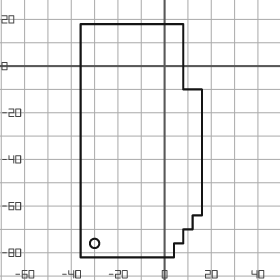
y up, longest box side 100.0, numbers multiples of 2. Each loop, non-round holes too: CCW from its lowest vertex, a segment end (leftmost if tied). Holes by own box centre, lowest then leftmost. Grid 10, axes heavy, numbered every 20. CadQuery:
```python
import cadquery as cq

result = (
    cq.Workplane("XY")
    .moveTo(-36.0, -82.0)
    .lineTo(4.0, -82.0)
    .lineTo(4.0, -76.0)
    .lineTo(8.0, -76.0)
    .lineTo(8.0, -70.0)
    .lineTo(12.0, -70.0)
    .lineTo(12.0, -64.0)
    .lineTo(16.0, -64.0)
    .lineTo(16.0, -10.0)
    .lineTo(8.0, -10.0)
    .lineTo(8.0, 18.0)
    .lineTo(-36.0, 18.0)
    .close()
    .moveTo(-30.0, -76.0)
    .circle(2.0)
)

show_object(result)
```